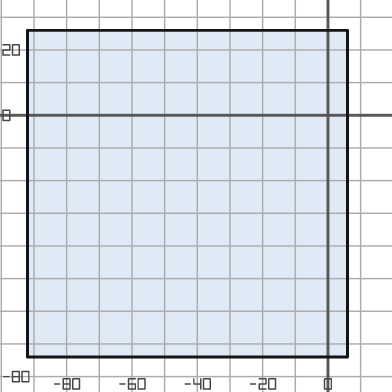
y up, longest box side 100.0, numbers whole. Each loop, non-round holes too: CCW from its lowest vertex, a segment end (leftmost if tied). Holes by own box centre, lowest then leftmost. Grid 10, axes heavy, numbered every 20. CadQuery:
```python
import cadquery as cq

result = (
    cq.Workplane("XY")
    .moveTo(-92.0, -74.0)
    .lineTo(6.0, -74.0)
    .lineTo(6.0, 26.0)
    .lineTo(-92.0, 26.0)
    .close()
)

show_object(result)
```